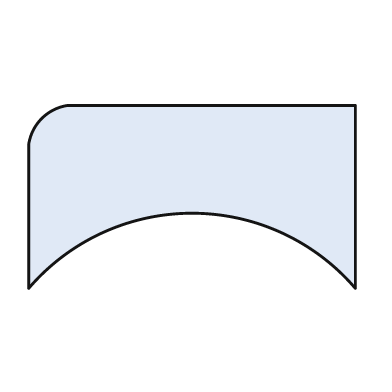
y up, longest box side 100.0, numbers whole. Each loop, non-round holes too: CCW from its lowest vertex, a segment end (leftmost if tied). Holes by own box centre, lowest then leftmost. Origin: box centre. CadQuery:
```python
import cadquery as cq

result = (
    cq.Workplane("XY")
    .moveTo(-50.0, -28.0)
    .threePointArc((0.0, -5.0), (50.0, -28.0))
    .lineTo(50.0, 28.0)
    .lineTo(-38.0, 28.0)
    .threePointArc((-46.0, 24.0), (-50.0, 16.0))
    .close()
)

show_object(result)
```